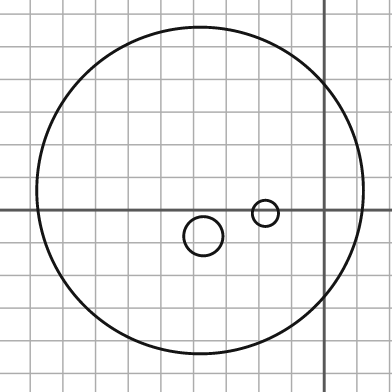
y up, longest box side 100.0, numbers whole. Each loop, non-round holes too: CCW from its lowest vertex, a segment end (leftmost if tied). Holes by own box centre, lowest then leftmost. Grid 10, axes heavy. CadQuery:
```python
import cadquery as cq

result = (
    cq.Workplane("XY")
    .moveTo(-38.0, 6.0)
    .circle(50.0)
    .moveTo(-37.0, -8.0)
    .circle(6.0)
    .moveTo(-18.0, -1.0)
    .circle(4.0)
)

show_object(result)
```